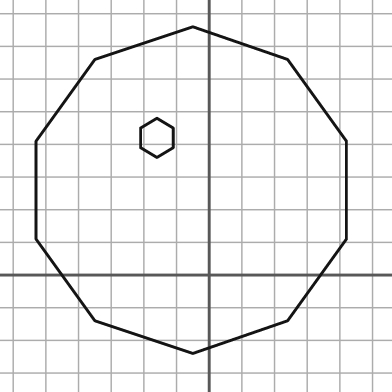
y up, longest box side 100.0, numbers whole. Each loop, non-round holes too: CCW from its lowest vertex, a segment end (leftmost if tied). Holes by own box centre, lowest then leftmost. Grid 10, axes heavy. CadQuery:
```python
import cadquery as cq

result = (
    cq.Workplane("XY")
    .moveTo(-5.0, -24.0)
    .lineTo(24.0, -14.0)
    .lineTo(42.0, 11.0)
    .lineTo(42.0, 41.0)
    .lineTo(24.0, 66.0)
    .lineTo(-5.0, 76.0)
    .lineTo(-35.0, 66.0)
    .lineTo(-53.0, 41.0)
    .lineTo(-53.0, 11.0)
    .lineTo(-35.0, -14.0)
    .close()
    .moveTo(-16.0, 36.0)
    .lineTo(-11.0, 39.0)
    .lineTo(-11.0, 45.0)
    .lineTo(-16.0, 48.0)
    .lineTo(-21.0, 45.0)
    .lineTo(-21.0, 39.0)
    .close()
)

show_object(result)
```